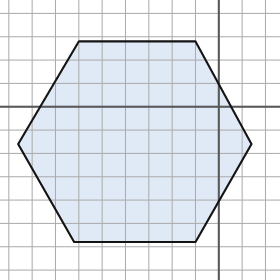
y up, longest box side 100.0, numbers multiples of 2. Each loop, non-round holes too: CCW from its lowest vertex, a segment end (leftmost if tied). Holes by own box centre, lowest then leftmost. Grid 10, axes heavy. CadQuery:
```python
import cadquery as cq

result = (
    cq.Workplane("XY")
    .moveTo(-62.0, -58.0)
    .lineTo(-10.0, -58.0)
    .lineTo(14.0, -16.0)
    .lineTo(-10.0, 28.0)
    .lineTo(-60.0, 28.0)
    .lineTo(-86.0, -16.0)
    .close()
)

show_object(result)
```